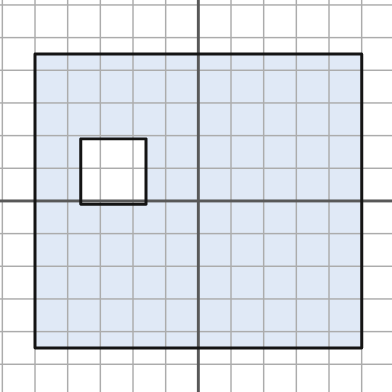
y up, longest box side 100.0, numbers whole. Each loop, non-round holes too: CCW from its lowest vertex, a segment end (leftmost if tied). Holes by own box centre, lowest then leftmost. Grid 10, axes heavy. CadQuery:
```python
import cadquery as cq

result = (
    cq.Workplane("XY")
    .moveTo(-50.0, -45.0)
    .lineTo(50.0, -45.0)
    .lineTo(50.0, 45.0)
    .lineTo(-50.0, 45.0)
    .close()
    .moveTo(-36.0, -1.0)
    .lineTo(-16.0, -1.0)
    .lineTo(-16.0, 19.0)
    .lineTo(-36.0, 19.0)
    .close()
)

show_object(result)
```